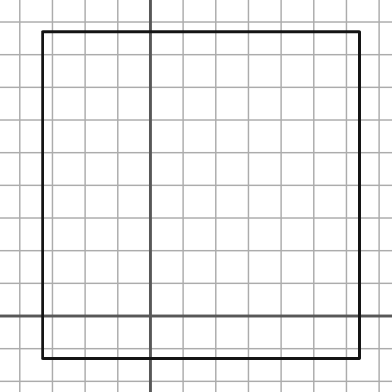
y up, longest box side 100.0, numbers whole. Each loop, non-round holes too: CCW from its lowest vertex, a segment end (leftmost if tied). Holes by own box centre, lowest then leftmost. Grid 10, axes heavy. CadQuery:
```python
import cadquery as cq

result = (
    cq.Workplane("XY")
    .moveTo(-33.0, -13.0)
    .lineTo(64.0, -13.0)
    .lineTo(64.0, 87.0)
    .lineTo(-33.0, 87.0)
    .close()
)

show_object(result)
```